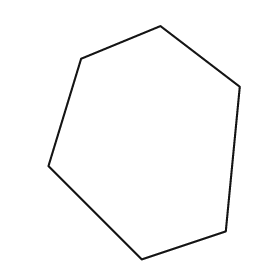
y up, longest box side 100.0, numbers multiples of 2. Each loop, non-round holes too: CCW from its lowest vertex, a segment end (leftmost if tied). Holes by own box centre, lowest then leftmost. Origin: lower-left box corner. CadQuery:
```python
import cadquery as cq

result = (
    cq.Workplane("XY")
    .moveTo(40.0, 0.0)
    .lineTo(76.0, 12.0)
    .lineTo(82.0, 74.0)
    .lineTo(48.0, 100.0)
    .lineTo(14.0, 86.0)
    .lineTo(0.0, 40.0)
    .close()
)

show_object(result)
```